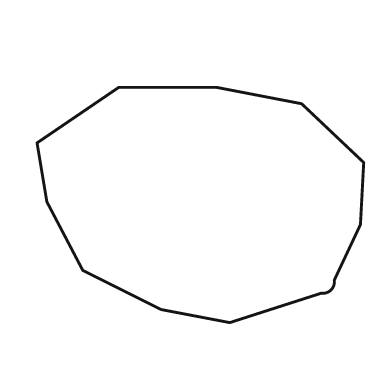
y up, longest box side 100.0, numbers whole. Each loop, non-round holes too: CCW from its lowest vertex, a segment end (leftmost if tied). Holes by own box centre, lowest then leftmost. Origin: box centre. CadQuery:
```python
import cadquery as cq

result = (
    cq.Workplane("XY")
    .moveTo(9.0, -36.0)
    .lineTo(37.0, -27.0)
    .threePointArc((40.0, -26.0), (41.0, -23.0))
    .lineTo(49.0, -6.0)
    .lineTo(50.0, 13.0)
    .lineTo(31.0, 31.0)
    .lineTo(5.0, 36.0)
    .lineTo(-25.0, 36.0)
    .lineTo(-50.0, 19.0)
    .lineTo(-47.0, 1.0)
    .lineTo(-36.0, -20.0)
    .lineTo(-12.0, -32.0)
    .close()
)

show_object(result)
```